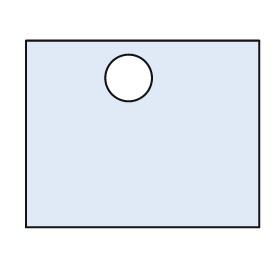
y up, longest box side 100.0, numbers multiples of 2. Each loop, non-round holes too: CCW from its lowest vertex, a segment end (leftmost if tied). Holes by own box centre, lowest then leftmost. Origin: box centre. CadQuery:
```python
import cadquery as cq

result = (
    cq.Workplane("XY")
    .moveTo(-50.0, -40.0)
    .lineTo(50.0, -40.0)
    .lineTo(50.0, 40.0)
    .lineTo(-50.0, 40.0)
    .close()
    .moveTo(-6.0, 24.0)
    .circle(10.0)
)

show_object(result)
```